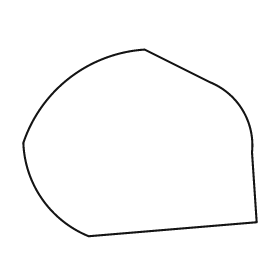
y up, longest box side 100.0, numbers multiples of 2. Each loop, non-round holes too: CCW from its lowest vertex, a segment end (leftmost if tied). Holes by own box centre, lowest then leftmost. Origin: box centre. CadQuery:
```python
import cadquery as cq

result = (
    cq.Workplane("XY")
    .moveTo(-22.0, -40.0)
    .lineTo(50.0, -34.0)
    .lineTo(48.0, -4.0)
    .threePointArc((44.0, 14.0), (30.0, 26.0))
    .lineTo(2.0, 40.0)
    .threePointArc((-30.0, 28.0), (-50.0, 0.0))
    .threePointArc((-42.0, -24.0), (-22.0, -40.0))
    .close()
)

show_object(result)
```